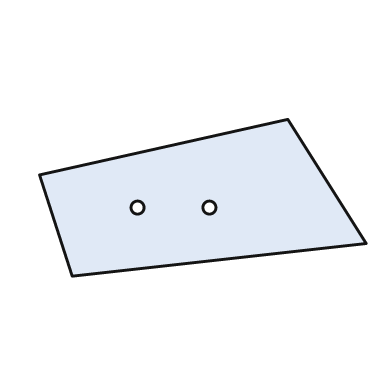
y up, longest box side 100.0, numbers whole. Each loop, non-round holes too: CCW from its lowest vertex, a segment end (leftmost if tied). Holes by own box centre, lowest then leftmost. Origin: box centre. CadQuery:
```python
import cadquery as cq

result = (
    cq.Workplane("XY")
    .moveTo(-40.0, -24.0)
    .lineTo(50.0, -14.0)
    .lineTo(26.0, 24.0)
    .lineTo(-50.0, 7.0)
    .close()
    .moveTo(-20.0, -3.0)
    .circle(2.0)
    .moveTo(2.0, -3.0)
    .circle(2.0)
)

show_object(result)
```